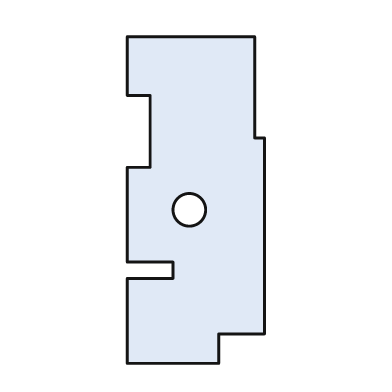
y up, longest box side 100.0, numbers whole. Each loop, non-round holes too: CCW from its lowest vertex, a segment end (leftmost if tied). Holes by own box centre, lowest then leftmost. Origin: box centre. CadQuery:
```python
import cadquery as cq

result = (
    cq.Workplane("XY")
    .moveTo(-21.0, -50.0)
    .lineTo(7.0, -50.0)
    .lineTo(7.0, -41.0)
    .lineTo(21.0, -41.0)
    .lineTo(21.0, 19.0)
    .lineTo(18.0, 19.0)
    .lineTo(18.0, 50.0)
    .lineTo(-21.0, 50.0)
    .lineTo(-21.0, 32.0)
    .lineTo(-14.0, 32.0)
    .lineTo(-14.0, 10.0)
    .lineTo(-21.0, 10.0)
    .lineTo(-21.0, -19.0)
    .lineTo(-7.0, -19.0)
    .lineTo(-7.0, -24.0)
    .lineTo(-21.0, -24.0)
    .close()
    .moveTo(-2.0, -3.0)
    .circle(5.0)
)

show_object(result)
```